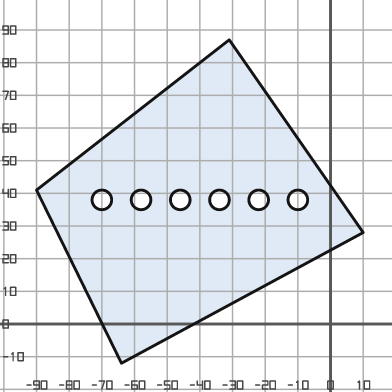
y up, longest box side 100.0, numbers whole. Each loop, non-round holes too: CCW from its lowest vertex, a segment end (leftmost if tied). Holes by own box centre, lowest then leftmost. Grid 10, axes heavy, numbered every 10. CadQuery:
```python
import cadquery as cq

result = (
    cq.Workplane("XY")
    .moveTo(-64.0, -12.0)
    .lineTo(10.0, 28.0)
    .lineTo(-31.0, 87.0)
    .lineTo(-90.0, 41.0)
    .close()
    .moveTo(-70.0, 38.0)
    .circle(3.0)
    .moveTo(-58.0, 38.0)
    .circle(3.0)
    .moveTo(-46.0, 38.0)
    .circle(3.0)
    .moveTo(-34.0, 38.0)
    .circle(3.0)
    .moveTo(-22.0, 38.0)
    .circle(3.0)
    .moveTo(-10.0, 38.0)
    .circle(3.0)
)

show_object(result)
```